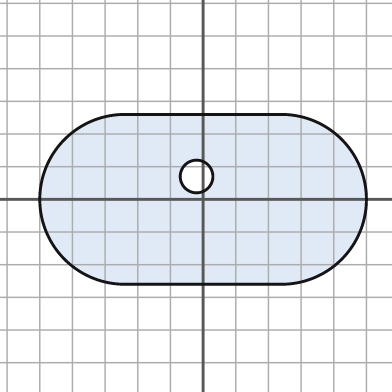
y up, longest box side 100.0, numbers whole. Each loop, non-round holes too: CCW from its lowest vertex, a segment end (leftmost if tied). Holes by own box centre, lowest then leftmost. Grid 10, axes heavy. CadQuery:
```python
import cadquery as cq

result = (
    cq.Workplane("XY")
    .moveTo(-24.0, -26.0)
    .lineTo(24.0, -26.0)
    .threePointArc((50.0, 0.0), (24.0, 26.0))
    .lineTo(-24.0, 26.0)
    .threePointArc((-50.0, 0.0), (-24.0, -26.0))
    .close()
    .moveTo(-2.0, 7.0)
    .circle(5.0)
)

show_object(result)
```